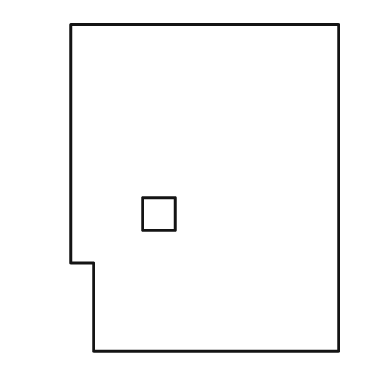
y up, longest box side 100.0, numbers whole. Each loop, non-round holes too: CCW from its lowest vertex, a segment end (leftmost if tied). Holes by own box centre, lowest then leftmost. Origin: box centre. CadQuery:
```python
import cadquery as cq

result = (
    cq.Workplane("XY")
    .moveTo(-34.0, -50.0)
    .lineTo(41.0, -50.0)
    .lineTo(41.0, 50.0)
    .lineTo(-41.0, 50.0)
    .lineTo(-41.0, -23.0)
    .lineTo(-34.0, -23.0)
    .close()
    .moveTo(-19.0, -13.0)
    .lineTo(-9.0, -13.0)
    .lineTo(-9.0, -3.0)
    .lineTo(-19.0, -3.0)
    .close()
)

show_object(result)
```